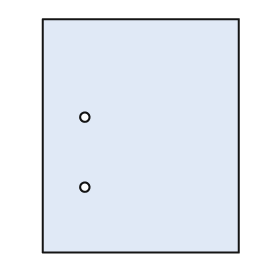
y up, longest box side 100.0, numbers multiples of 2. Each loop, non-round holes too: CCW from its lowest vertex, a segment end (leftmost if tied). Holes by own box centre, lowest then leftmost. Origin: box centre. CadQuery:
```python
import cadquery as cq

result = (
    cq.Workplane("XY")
    .moveTo(-42.0, -50.0)
    .lineTo(42.0, -50.0)
    .lineTo(42.0, 50.0)
    .lineTo(-42.0, 50.0)
    .close()
    .moveTo(-24.0, -22.0)
    .circle(2.0)
    .moveTo(-24.0, 8.0)
    .circle(2.0)
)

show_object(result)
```